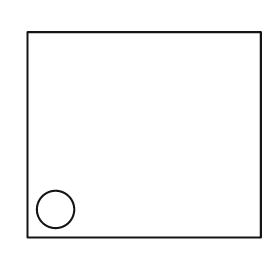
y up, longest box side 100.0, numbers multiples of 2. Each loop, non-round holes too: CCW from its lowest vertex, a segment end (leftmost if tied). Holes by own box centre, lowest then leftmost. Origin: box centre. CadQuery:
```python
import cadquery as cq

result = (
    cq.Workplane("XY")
    .moveTo(-50.0, -44.0)
    .lineTo(50.0, -44.0)
    .lineTo(50.0, 44.0)
    .lineTo(-50.0, 44.0)
    .close()
    .moveTo(-38.0, -32.0)
    .circle(8.0)
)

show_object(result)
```